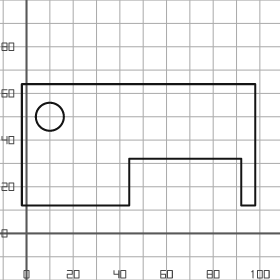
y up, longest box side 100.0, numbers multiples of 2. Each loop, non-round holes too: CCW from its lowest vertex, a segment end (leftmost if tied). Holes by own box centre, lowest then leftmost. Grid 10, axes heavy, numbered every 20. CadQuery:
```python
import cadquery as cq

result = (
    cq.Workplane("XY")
    .moveTo(-2.0, 12.0)
    .lineTo(44.0, 12.0)
    .lineTo(44.0, 32.0)
    .lineTo(92.0, 32.0)
    .lineTo(92.0, 12.0)
    .lineTo(98.0, 12.0)
    .lineTo(98.0, 64.0)
    .lineTo(-2.0, 64.0)
    .close()
    .moveTo(10.0, 50.0)
    .circle(6.0)
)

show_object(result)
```